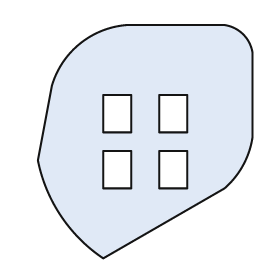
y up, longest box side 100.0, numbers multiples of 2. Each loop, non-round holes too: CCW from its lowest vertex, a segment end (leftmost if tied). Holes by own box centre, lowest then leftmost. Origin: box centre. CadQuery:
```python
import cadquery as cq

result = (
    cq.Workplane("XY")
    .moveTo(-18.0, -50.0)
    .lineTo(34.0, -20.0)
    .threePointArc((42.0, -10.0), (46.0, 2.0))
    .lineTo(46.0, 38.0)
    .threePointArc((42.0, 46.0), (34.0, 50.0))
    .lineTo(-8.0, 50.0)
    .threePointArc((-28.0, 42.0), (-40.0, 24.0))
    .lineTo(-46.0, -8.0)
    .threePointArc((-36.0, -32.0), (-18.0, -50.0))
    .close()
    .moveTo(-18.0, -20.0)
    .lineTo(-6.0, -20.0)
    .lineTo(-6.0, -4.0)
    .lineTo(-18.0, -4.0)
    .close()
    .moveTo(6.0, -20.0)
    .lineTo(18.0, -20.0)
    .lineTo(18.0, -4.0)
    .lineTo(6.0, -4.0)
    .close()
    .moveTo(-18.0, 4.0)
    .lineTo(-6.0, 4.0)
    .lineTo(-6.0, 20.0)
    .lineTo(-18.0, 20.0)
    .close()
    .moveTo(6.0, 4.0)
    .lineTo(18.0, 4.0)
    .lineTo(18.0, 20.0)
    .lineTo(6.0, 20.0)
    .close()
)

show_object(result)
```